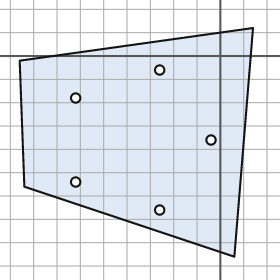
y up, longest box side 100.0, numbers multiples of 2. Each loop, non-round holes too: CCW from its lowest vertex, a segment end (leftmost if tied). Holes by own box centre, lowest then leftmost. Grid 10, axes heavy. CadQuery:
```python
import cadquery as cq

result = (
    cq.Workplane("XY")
    .moveTo(6.0, -86.0)
    .lineTo(14.0, 12.0)
    .lineTo(-86.0, -2.0)
    .lineTo(-84.0, -56.0)
    .close()
    .moveTo(-26.0, -66.0)
    .circle(2.0)
    .moveTo(-62.0, -54.0)
    .circle(2.0)
    .moveTo(-4.0, -36.0)
    .circle(2.0)
    .moveTo(-62.0, -18.0)
    .circle(2.0)
    .moveTo(-26.0, -6.0)
    .circle(2.0)
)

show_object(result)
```